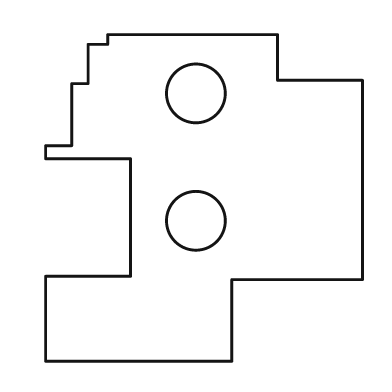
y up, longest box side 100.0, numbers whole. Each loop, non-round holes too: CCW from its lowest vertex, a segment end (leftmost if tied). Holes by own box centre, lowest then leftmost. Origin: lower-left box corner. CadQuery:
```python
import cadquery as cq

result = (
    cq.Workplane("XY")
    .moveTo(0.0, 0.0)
    .lineTo(57.0, 0.0)
    .lineTo(57.0, 25.0)
    .lineTo(97.0, 25.0)
    .lineTo(97.0, 86.0)
    .lineTo(71.0, 86.0)
    .lineTo(71.0, 100.0)
    .lineTo(19.0, 100.0)
    .lineTo(19.0, 97.0)
    .lineTo(13.0, 97.0)
    .lineTo(13.0, 85.0)
    .lineTo(8.0, 85.0)
    .lineTo(8.0, 66.0)
    .lineTo(0.0, 66.0)
    .lineTo(0.0, 62.0)
    .lineTo(26.0, 62.0)
    .lineTo(26.0, 26.0)
    .lineTo(0.0, 26.0)
    .close()
    .moveTo(46.0, 43.0)
    .circle(9.0)
    .moveTo(46.0, 82.0)
    .circle(9.0)
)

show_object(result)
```